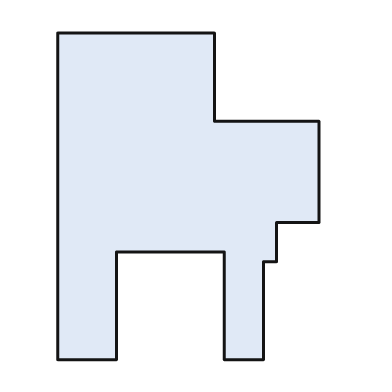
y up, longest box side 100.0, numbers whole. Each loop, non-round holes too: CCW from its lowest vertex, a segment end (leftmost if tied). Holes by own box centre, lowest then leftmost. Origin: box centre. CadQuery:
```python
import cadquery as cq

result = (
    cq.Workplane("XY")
    .moveTo(-40.0, -50.0)
    .lineTo(-22.0, -50.0)
    .lineTo(-22.0, -17.0)
    .lineTo(11.0, -17.0)
    .lineTo(11.0, -50.0)
    .lineTo(23.0, -50.0)
    .lineTo(23.0, -20.0)
    .lineTo(27.0, -20.0)
    .lineTo(27.0, -8.0)
    .lineTo(40.0, -8.0)
    .lineTo(40.0, 23.0)
    .lineTo(8.0, 23.0)
    .lineTo(8.0, 50.0)
    .lineTo(-40.0, 50.0)
    .close()
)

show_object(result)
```